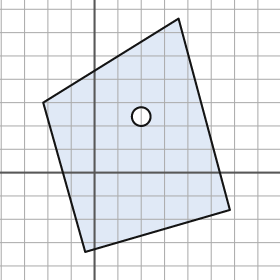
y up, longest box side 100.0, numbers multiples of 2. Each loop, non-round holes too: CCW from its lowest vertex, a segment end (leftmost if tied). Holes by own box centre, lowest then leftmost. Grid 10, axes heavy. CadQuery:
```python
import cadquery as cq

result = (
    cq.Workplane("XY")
    .moveTo(-4.0, -34.0)
    .lineTo(58.0, -16.0)
    .lineTo(36.0, 66.0)
    .lineTo(-22.0, 30.0)
    .close()
    .moveTo(20.0, 24.0)
    .circle(4.0)
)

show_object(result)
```